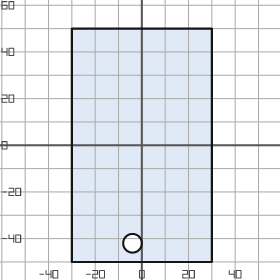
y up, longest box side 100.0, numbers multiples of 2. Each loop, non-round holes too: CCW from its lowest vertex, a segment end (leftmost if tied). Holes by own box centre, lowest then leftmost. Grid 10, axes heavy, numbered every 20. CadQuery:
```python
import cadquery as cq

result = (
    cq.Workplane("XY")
    .moveTo(-30.0, -50.0)
    .lineTo(30.0, -50.0)
    .lineTo(30.0, 50.0)
    .lineTo(-30.0, 50.0)
    .close()
    .moveTo(-4.0, -42.0)
    .circle(4.0)
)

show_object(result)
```